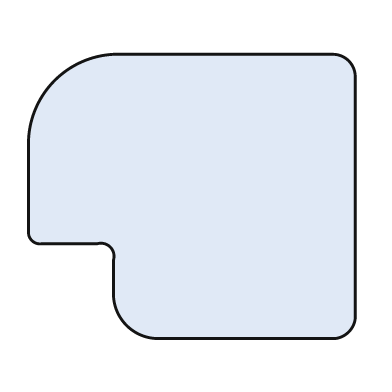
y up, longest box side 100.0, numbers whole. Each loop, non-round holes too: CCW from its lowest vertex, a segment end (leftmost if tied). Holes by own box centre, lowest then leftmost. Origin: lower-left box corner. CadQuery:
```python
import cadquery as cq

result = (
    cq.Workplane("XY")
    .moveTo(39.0, 0.0)
    .lineTo(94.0, 0.0)
    .threePointArc((98.0, 2.0), (100.0, 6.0))
    .lineTo(100.0, 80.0)
    .threePointArc((98.0, 85.0), (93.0, 87.0))
    .lineTo(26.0, 87.0)
    .threePointArc((8.0, 79.0), (0.0, 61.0))
    .lineTo(0.0, 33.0)
    .threePointArc((1.0, 30.0), (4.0, 29.0))
    .lineTo(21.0, 29.0)
    .threePointArc((25.0, 28.0), (26.0, 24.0))
    .lineTo(26.0, 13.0)
    .threePointArc((30.0, 4.0), (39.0, 0.0))
    .close()
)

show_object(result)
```